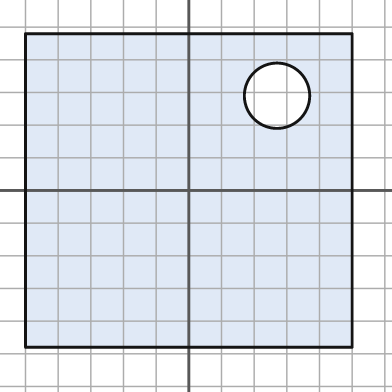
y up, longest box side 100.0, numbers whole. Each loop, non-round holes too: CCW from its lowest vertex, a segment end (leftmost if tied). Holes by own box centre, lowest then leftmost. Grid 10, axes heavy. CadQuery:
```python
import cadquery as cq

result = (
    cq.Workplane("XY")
    .moveTo(-50.0, -48.0)
    .lineTo(50.0, -48.0)
    .lineTo(50.0, 48.0)
    .lineTo(-50.0, 48.0)
    .close()
    .moveTo(27.0, 29.0)
    .circle(10.0)
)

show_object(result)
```